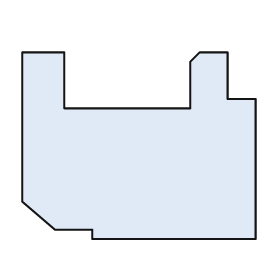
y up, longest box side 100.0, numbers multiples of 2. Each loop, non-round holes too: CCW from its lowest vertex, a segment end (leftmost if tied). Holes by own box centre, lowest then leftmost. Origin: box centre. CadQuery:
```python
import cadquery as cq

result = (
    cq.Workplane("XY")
    .moveTo(-20.0, -40.0)
    .lineTo(50.0, -40.0)
    .lineTo(50.0, 20.0)
    .lineTo(38.0, 20.0)
    .lineTo(38.0, 40.0)
    .lineTo(26.0, 40.0)
    .lineTo(22.0, 36.0)
    .lineTo(22.0, 16.0)
    .lineTo(-32.0, 16.0)
    .lineTo(-32.0, 40.0)
    .lineTo(-50.0, 40.0)
    .lineTo(-50.0, -24.0)
    .lineTo(-36.0, -36.0)
    .lineTo(-20.0, -36.0)
    .close()
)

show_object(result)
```